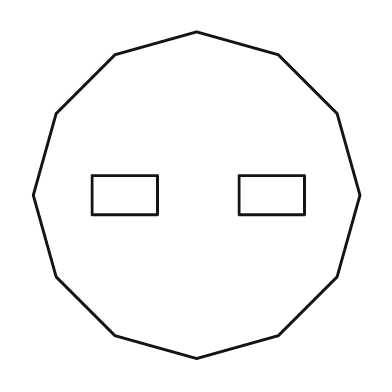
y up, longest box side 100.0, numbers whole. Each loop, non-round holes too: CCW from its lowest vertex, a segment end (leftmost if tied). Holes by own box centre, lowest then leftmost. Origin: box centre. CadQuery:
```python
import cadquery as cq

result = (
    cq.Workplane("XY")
    .moveTo(0.0, -50.0)
    .lineTo(25.0, -43.0)
    .lineTo(43.0, -25.0)
    .lineTo(50.0, 0.0)
    .lineTo(43.0, 25.0)
    .lineTo(25.0, 43.0)
    .lineTo(0.0, 50.0)
    .lineTo(-25.0, 43.0)
    .lineTo(-43.0, 25.0)
    .lineTo(-50.0, 0.0)
    .lineTo(-43.0, -25.0)
    .lineTo(-25.0, -43.0)
    .close()
    .moveTo(-32.0, -6.0)
    .lineTo(-12.0, -6.0)
    .lineTo(-12.0, 6.0)
    .lineTo(-32.0, 6.0)
    .close()
    .moveTo(13.0, -6.0)
    .lineTo(33.0, -6.0)
    .lineTo(33.0, 6.0)
    .lineTo(13.0, 6.0)
    .close()
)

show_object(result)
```